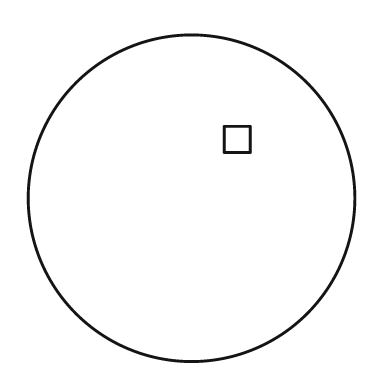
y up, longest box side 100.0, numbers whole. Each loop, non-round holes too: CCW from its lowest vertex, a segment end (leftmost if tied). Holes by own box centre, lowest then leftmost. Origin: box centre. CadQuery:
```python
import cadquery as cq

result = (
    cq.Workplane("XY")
    .moveTo(0.0, 0.0)
    .circle(50.0)
    .moveTo(10.0, 14.0)
    .lineTo(18.0, 14.0)
    .lineTo(18.0, 22.0)
    .lineTo(10.0, 22.0)
    .close()
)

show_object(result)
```